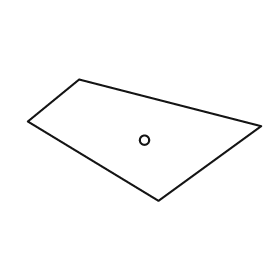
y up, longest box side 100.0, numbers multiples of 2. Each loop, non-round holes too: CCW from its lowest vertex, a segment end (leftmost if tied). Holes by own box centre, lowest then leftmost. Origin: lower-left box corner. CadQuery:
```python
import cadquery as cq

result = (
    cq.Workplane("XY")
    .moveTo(56.0, 0.0)
    .lineTo(100.0, 32.0)
    .lineTo(22.0, 52.0)
    .lineTo(0.0, 34.0)
    .close()
    .moveTo(50.0, 26.0)
    .circle(2.0)
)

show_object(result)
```